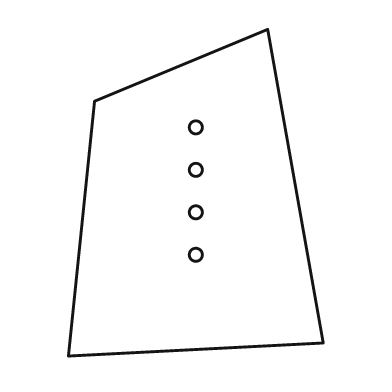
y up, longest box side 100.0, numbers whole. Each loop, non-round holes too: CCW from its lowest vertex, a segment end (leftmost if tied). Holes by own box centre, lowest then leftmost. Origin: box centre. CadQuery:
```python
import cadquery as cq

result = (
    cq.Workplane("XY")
    .moveTo(-39.0, -50.0)
    .lineTo(39.0, -46.0)
    .lineTo(22.0, 50.0)
    .lineTo(-31.0, 28.0)
    .close()
    .moveTo(0.0, -19.0)
    .circle(2.0)
    .moveTo(0.0, -6.0)
    .circle(2.0)
    .moveTo(0.0, 7.0)
    .circle(2.0)
    .moveTo(0.0, 20.0)
    .circle(2.0)
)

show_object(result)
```